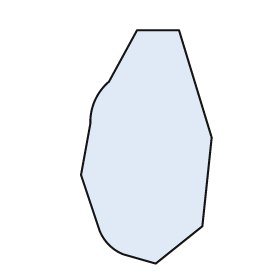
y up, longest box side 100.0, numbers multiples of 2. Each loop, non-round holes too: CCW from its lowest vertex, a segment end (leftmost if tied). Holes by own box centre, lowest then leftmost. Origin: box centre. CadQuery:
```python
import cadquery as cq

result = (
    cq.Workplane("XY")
    .moveTo(4.0, -50.0)
    .lineTo(24.0, -34.0)
    .lineTo(28.0, 4.0)
    .lineTo(14.0, 50.0)
    .lineTo(-4.0, 50.0)
    .lineTo(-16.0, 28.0)
    .threePointArc((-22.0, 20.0), (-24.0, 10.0))
    .lineTo(-28.0, -12.0)
    .lineTo(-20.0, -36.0)
    .threePointArc((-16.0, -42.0), (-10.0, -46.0))
    .close()
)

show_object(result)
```